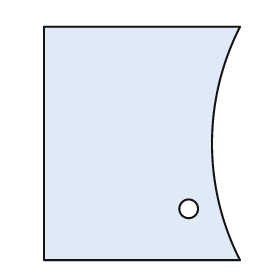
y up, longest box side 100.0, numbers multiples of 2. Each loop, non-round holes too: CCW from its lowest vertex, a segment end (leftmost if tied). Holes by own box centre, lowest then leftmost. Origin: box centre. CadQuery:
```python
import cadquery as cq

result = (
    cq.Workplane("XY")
    .moveTo(-42.0, -50.0)
    .lineTo(42.0, -50.0)
    .threePointArc((30.0, 0.0), (42.0, 50.0))
    .lineTo(-42.0, 50.0)
    .close()
    .moveTo(20.0, -28.0)
    .circle(4.0)
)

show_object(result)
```